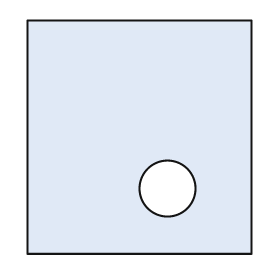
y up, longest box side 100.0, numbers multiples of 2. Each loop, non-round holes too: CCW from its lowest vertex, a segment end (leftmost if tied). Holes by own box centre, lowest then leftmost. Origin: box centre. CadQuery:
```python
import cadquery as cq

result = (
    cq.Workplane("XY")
    .moveTo(-48.0, -50.0)
    .lineTo(48.0, -50.0)
    .lineTo(48.0, 50.0)
    .lineTo(-48.0, 50.0)
    .close()
    .moveTo(12.0, -22.0)
    .circle(12.0)
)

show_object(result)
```